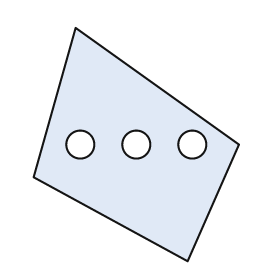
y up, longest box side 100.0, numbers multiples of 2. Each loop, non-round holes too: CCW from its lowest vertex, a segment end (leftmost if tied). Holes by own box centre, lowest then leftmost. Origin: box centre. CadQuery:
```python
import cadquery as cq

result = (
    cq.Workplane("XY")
    .moveTo(22.0, -50.0)
    .lineTo(44.0, 0.0)
    .lineTo(-26.0, 50.0)
    .lineTo(-44.0, -14.0)
    .close()
    .moveTo(-24.0, 0.0)
    .circle(6.0)
    .moveTo(0.0, 0.0)
    .circle(6.0)
    .moveTo(24.0, 0.0)
    .circle(6.0)
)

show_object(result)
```